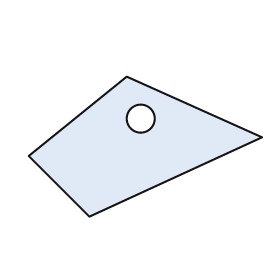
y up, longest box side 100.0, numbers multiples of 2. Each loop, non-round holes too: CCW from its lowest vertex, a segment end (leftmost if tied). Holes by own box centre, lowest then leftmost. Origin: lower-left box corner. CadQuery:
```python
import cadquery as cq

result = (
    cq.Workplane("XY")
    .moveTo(26.0, 0.0)
    .lineTo(100.0, 34.0)
    .lineTo(42.0, 60.0)
    .lineTo(0.0, 26.0)
    .close()
    .moveTo(48.0, 42.0)
    .circle(6.0)
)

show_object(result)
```